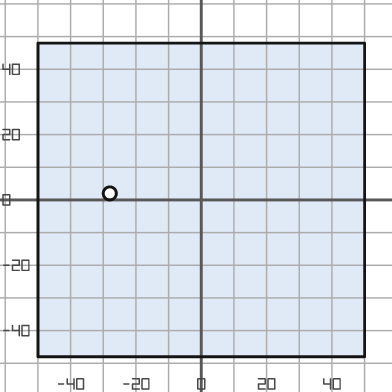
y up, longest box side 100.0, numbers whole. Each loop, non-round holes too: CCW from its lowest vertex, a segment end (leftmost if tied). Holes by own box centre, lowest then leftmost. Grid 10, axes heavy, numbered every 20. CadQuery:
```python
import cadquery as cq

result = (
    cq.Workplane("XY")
    .moveTo(-50.0, -48.0)
    .lineTo(50.0, -48.0)
    .lineTo(50.0, 48.0)
    .lineTo(-50.0, 48.0)
    .close()
    .moveTo(-28.0, 2.0)
    .circle(2.0)
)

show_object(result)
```